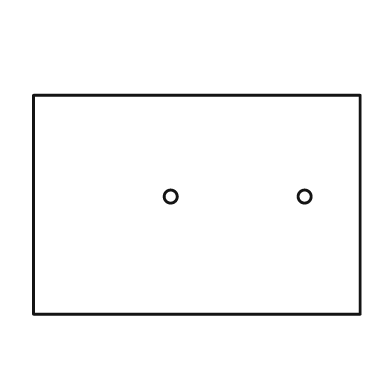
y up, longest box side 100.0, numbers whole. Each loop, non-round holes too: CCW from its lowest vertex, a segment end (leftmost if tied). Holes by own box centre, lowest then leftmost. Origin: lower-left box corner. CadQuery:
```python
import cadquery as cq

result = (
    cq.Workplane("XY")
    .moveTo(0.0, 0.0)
    .lineTo(100.0, 0.0)
    .lineTo(100.0, 67.0)
    .lineTo(0.0, 67.0)
    .close()
    .moveTo(42.0, 36.0)
    .circle(2.0)
    .moveTo(83.0, 36.0)
    .circle(2.0)
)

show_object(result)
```